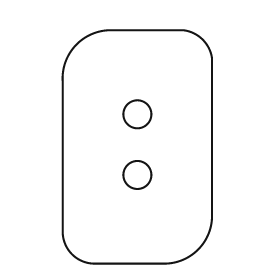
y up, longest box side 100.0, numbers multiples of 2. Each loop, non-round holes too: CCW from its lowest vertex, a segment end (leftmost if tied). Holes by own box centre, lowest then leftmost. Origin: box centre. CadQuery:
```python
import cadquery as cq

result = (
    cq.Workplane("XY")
    .moveTo(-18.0, -50.0)
    .lineTo(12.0, -50.0)
    .threePointArc((26.0, -44.0), (32.0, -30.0))
    .lineTo(32.0, 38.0)
    .threePointArc((28.0, 46.0), (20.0, 50.0))
    .lineTo(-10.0, 50.0)
    .threePointArc((-26.0, 44.0), (-32.0, 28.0))
    .lineTo(-32.0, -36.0)
    .threePointArc((-28.0, -46.0), (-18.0, -50.0))
    .close()
    .moveTo(0.0, -12.0)
    .circle(6.0)
    .moveTo(0.0, 14.0)
    .circle(6.0)
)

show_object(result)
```